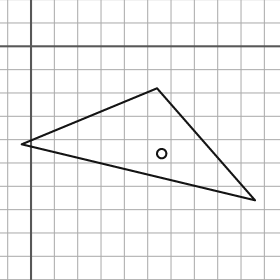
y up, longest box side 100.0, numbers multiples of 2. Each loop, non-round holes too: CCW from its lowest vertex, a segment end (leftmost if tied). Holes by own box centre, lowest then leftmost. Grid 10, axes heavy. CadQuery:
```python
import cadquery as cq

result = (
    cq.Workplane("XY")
    .moveTo(96.0, -66.0)
    .lineTo(54.0, -18.0)
    .lineTo(-4.0, -42.0)
    .close()
    .moveTo(56.0, -46.0)
    .circle(2.0)
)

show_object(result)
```